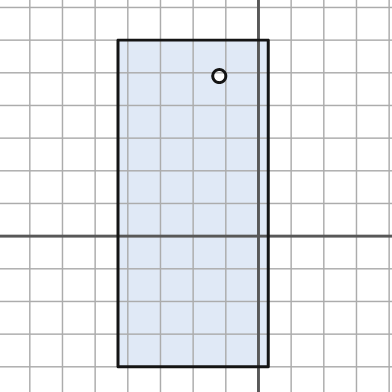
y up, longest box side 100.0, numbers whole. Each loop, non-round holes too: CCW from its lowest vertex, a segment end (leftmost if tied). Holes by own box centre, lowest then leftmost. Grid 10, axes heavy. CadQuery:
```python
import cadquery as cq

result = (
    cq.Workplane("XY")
    .moveTo(-43.0, -40.0)
    .lineTo(3.0, -40.0)
    .lineTo(3.0, 60.0)
    .lineTo(-43.0, 60.0)
    .close()
    .moveTo(-12.0, 49.0)
    .circle(2.0)
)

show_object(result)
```